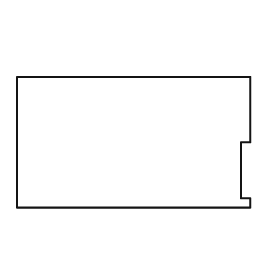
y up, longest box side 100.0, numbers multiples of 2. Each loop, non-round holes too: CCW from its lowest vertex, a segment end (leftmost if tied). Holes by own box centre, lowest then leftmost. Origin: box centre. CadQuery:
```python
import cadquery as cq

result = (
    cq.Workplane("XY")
    .moveTo(-50.0, -28.0)
    .lineTo(50.0, -28.0)
    .lineTo(50.0, -24.0)
    .lineTo(46.0, -24.0)
    .lineTo(46.0, 0.0)
    .lineTo(50.0, 0.0)
    .lineTo(50.0, 28.0)
    .lineTo(-50.0, 28.0)
    .close()
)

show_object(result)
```